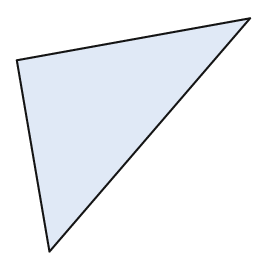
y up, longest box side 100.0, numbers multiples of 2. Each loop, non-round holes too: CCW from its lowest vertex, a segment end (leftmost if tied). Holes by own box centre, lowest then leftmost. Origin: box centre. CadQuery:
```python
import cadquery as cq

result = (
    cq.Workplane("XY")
    .moveTo(-36.0, -50.0)
    .lineTo(50.0, 50.0)
    .lineTo(-50.0, 32.0)
    .close()
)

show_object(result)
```